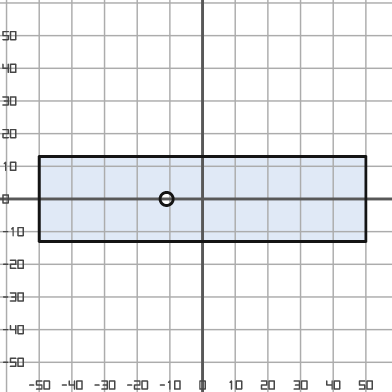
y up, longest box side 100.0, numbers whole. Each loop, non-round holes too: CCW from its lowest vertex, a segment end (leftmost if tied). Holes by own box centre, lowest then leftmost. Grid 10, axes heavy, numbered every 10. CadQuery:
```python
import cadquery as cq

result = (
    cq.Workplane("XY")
    .moveTo(-50.0, -13.0)
    .lineTo(50.0, -13.0)
    .lineTo(50.0, 13.0)
    .lineTo(-50.0, 13.0)
    .close()
    .moveTo(-11.0, 0.0)
    .circle(2.0)
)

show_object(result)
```